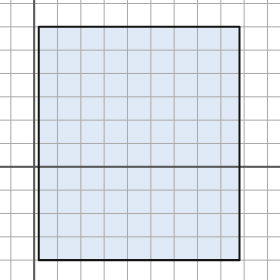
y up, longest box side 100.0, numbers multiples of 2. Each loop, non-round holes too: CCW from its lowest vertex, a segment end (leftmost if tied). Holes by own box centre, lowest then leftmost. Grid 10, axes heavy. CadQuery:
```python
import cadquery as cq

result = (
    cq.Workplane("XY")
    .moveTo(2.0, -40.0)
    .lineTo(88.0, -40.0)
    .lineTo(88.0, 60.0)
    .lineTo(2.0, 60.0)
    .close()
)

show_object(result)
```